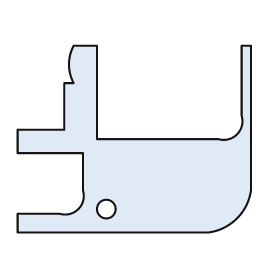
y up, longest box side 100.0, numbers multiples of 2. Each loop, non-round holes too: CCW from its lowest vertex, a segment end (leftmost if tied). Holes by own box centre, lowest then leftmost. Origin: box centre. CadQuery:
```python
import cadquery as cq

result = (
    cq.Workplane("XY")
    .moveTo(-50.0, -40.0)
    .lineTo(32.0, -40.0)
    .threePointArc((44.0, -34.0), (50.0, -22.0))
    .lineTo(50.0, 40.0)
    .lineTo(46.0, 40.0)
    .lineTo(46.0, 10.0)
    .threePointArc((44.0, 2.0), (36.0, 0.0))
    .lineTo(-16.0, 0.0)
    .lineTo(-16.0, 40.0)
    .lineTo(-26.0, 40.0)
    .threePointArc((-28.0, 32.0), (-26.0, 24.0))
    .lineTo(-30.0, 24.0)
    .lineTo(-30.0, 4.0)
    .lineTo(-50.0, 4.0)
    .lineTo(-50.0, -6.0)
    .lineTo(-22.0, -6.0)
    .lineTo(-22.0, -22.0)
    .threePointArc((-24.0, -30.0), (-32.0, -32.0))
    .lineTo(-50.0, -32.0)
    .close()
    .moveTo(-12.0, -30.0)
    .circle(4.0)
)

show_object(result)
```